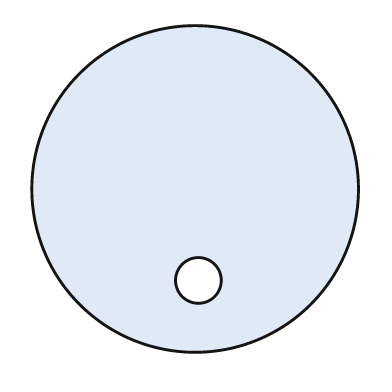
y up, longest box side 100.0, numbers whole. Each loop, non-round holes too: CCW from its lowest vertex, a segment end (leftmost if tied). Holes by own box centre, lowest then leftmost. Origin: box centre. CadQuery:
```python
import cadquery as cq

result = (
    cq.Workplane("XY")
    .moveTo(0.0, 0.0)
    .circle(50.0)
    .moveTo(1.0, -28.0)
    .circle(7.0)
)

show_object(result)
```